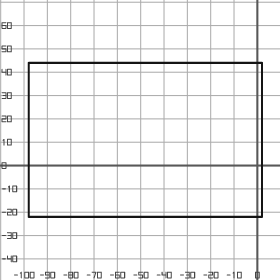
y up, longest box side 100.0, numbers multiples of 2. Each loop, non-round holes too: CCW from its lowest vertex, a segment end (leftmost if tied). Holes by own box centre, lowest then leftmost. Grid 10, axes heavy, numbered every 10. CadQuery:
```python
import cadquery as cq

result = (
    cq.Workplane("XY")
    .moveTo(-98.0, -22.0)
    .lineTo(2.0, -22.0)
    .lineTo(2.0, 44.0)
    .lineTo(-98.0, 44.0)
    .close()
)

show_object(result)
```